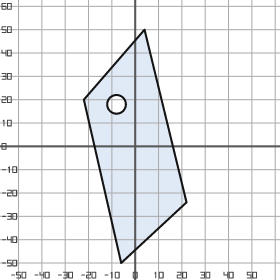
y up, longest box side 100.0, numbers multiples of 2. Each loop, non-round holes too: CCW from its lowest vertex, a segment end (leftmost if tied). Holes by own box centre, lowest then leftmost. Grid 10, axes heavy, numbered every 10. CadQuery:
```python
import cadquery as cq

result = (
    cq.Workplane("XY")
    .moveTo(-6.0, -50.0)
    .lineTo(22.0, -24.0)
    .lineTo(4.0, 50.0)
    .lineTo(-22.0, 20.0)
    .close()
    .moveTo(-8.0, 18.0)
    .circle(4.0)
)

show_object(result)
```